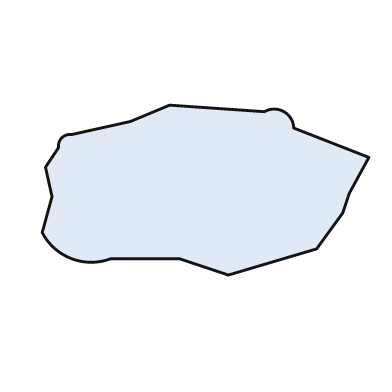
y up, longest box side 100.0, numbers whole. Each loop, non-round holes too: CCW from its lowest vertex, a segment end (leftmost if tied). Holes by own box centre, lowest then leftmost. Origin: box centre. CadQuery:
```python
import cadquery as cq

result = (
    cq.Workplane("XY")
    .moveTo(7.0, -26.0)
    .lineTo(34.0, -18.0)
    .lineTo(42.0, -7.0)
    .lineTo(44.0, -1.0)
    .lineTo(50.0, 10.0)
    .lineTo(27.0, 19.0)
    .threePointArc((24.0, 24.0), (18.0, 24.0))
    .lineTo(-11.0, 26.0)
    .lineTo(-23.0, 21.0)
    .lineTo(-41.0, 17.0)
    .threePointArc((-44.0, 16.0), (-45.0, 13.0))
    .lineTo(-49.0, 7.0)
    .lineTo(-47.0, -2.0)
    .lineTo(-50.0, -13.0)
    .threePointArc((-41.0, -21.0), (-29.0, -21.0))
    .lineTo(-8.0, -21.0)
    .close()
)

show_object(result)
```